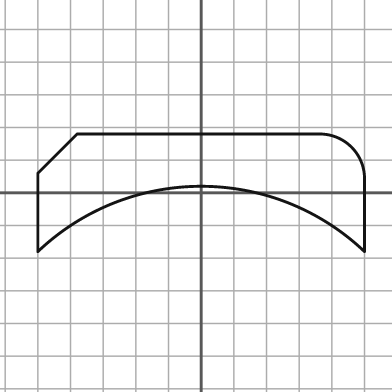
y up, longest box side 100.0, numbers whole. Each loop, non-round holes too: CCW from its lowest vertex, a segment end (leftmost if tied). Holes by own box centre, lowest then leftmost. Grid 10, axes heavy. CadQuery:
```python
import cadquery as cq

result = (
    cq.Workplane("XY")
    .moveTo(-50.0, -18.0)
    .threePointArc((0.0, 2.0), (50.0, -18.0))
    .lineTo(50.0, 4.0)
    .threePointArc((46.0, 14.0), (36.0, 18.0))
    .lineTo(-38.0, 18.0)
    .lineTo(-50.0, 6.0)
    .close()
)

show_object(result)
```